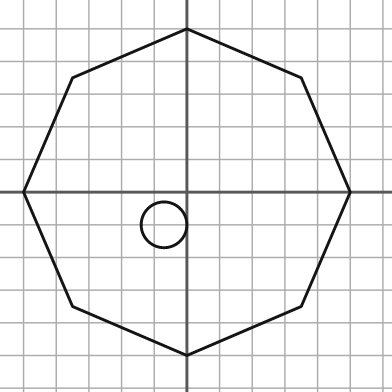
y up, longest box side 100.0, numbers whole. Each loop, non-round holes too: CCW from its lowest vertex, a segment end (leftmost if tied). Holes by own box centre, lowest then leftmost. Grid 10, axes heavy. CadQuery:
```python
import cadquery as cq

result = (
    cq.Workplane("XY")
    .moveTo(0.0, -50.0)
    .lineTo(35.0, -35.0)
    .lineTo(50.0, 0.0)
    .lineTo(35.0, 35.0)
    .lineTo(0.0, 50.0)
    .lineTo(-35.0, 35.0)
    .lineTo(-50.0, 0.0)
    .lineTo(-35.0, -35.0)
    .close()
    .moveTo(-7.0, -10.0)
    .circle(7.0)
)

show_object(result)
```